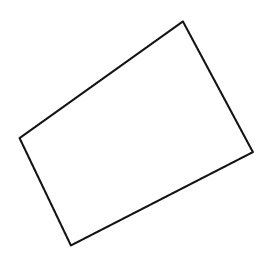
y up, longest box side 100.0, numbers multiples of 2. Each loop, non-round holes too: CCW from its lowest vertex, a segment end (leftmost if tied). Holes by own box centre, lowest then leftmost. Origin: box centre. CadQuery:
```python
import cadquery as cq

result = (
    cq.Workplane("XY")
    .moveTo(-28.0, -48.0)
    .lineTo(50.0, -8.0)
    .lineTo(20.0, 48.0)
    .lineTo(-50.0, -2.0)
    .close()
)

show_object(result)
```